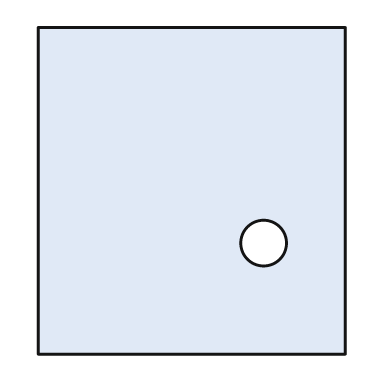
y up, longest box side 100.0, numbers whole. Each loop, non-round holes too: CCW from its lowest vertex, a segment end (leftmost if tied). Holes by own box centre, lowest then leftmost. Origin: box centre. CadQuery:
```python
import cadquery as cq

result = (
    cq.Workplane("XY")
    .moveTo(-47.0, -50.0)
    .lineTo(47.0, -50.0)
    .lineTo(47.0, 50.0)
    .lineTo(-47.0, 50.0)
    .close()
    .moveTo(22.0, -16.0)
    .circle(7.0)
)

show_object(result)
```